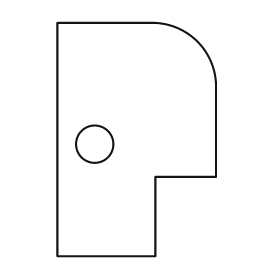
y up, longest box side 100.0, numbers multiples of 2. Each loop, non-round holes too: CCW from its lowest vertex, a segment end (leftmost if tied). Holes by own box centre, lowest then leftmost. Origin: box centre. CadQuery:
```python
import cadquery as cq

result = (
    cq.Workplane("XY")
    .moveTo(-34.0, -50.0)
    .lineTo(8.0, -50.0)
    .lineTo(8.0, -16.0)
    .lineTo(34.0, -16.0)
    .lineTo(34.0, 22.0)
    .threePointArc((26.0, 42.0), (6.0, 50.0))
    .lineTo(-34.0, 50.0)
    .close()
    .moveTo(-18.0, -2.0)
    .circle(8.0)
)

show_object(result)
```